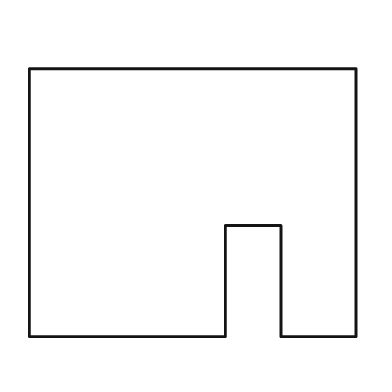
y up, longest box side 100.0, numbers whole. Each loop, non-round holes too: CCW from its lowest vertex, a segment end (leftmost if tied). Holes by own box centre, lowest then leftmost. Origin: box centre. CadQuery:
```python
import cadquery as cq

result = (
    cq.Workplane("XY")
    .moveTo(-50.0, -41.0)
    .lineTo(10.0, -41.0)
    .lineTo(10.0, -7.0)
    .lineTo(27.0, -7.0)
    .lineTo(27.0, -41.0)
    .lineTo(50.0, -41.0)
    .lineTo(50.0, 41.0)
    .lineTo(-50.0, 41.0)
    .close()
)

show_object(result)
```